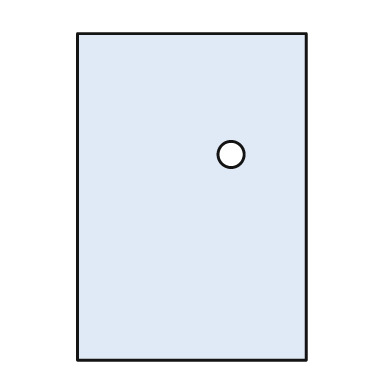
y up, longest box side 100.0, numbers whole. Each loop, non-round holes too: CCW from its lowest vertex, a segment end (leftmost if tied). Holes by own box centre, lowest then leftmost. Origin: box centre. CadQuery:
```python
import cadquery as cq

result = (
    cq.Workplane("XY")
    .moveTo(-35.0, -50.0)
    .lineTo(35.0, -50.0)
    .lineTo(35.0, 50.0)
    .lineTo(-35.0, 50.0)
    .close()
    .moveTo(12.0, 13.0)
    .circle(4.0)
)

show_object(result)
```